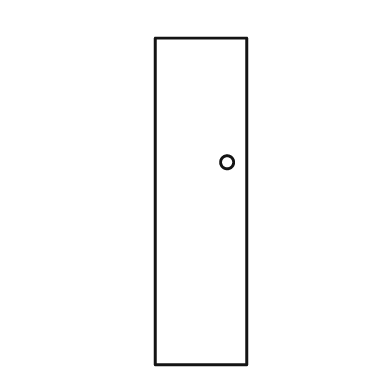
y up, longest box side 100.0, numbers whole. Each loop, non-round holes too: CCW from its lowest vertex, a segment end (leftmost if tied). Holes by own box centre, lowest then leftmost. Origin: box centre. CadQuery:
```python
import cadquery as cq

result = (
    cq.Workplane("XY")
    .moveTo(-14.0, -50.0)
    .lineTo(14.0, -50.0)
    .lineTo(14.0, 50.0)
    .lineTo(-14.0, 50.0)
    .close()
    .moveTo(8.0, 12.0)
    .circle(2.0)
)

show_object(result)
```